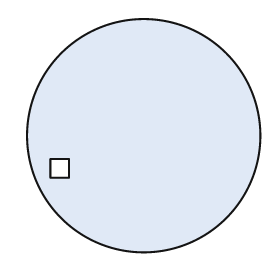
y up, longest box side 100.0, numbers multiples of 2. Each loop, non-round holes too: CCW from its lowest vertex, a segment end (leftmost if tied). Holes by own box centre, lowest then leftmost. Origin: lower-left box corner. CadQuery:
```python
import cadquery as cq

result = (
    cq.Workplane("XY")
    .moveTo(50.0, 50.0)
    .circle(50.0)
    .moveTo(10.0, 32.0)
    .lineTo(18.0, 32.0)
    .lineTo(18.0, 40.0)
    .lineTo(10.0, 40.0)
    .close()
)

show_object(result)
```